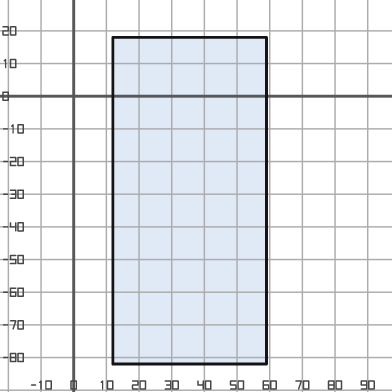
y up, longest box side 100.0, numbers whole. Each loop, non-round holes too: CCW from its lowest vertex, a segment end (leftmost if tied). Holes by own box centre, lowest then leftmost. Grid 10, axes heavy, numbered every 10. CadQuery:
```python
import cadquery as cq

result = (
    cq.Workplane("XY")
    .moveTo(12.0, -82.0)
    .lineTo(59.0, -82.0)
    .lineTo(59.0, 18.0)
    .lineTo(12.0, 18.0)
    .close()
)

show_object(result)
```